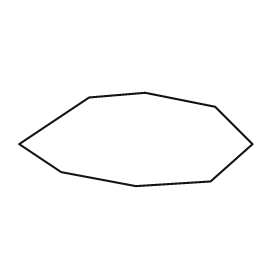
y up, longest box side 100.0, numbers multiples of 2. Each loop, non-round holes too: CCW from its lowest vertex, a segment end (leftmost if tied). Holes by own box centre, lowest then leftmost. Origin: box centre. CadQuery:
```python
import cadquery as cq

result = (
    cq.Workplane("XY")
    .moveTo(0.0, -20.0)
    .lineTo(32.0, -18.0)
    .lineTo(50.0, -2.0)
    .lineTo(34.0, 14.0)
    .lineTo(4.0, 20.0)
    .lineTo(-20.0, 18.0)
    .lineTo(-50.0, -2.0)
    .lineTo(-32.0, -14.0)
    .close()
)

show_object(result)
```